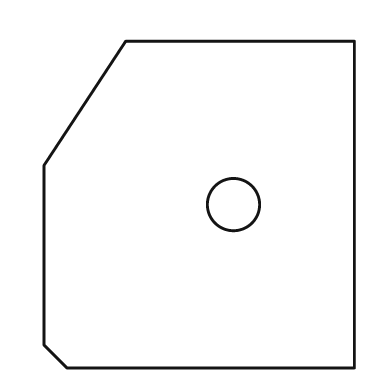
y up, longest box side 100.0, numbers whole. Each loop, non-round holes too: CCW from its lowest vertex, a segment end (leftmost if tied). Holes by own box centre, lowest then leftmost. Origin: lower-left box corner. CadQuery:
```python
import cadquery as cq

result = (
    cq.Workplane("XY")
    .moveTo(7.0, 0.0)
    .lineTo(95.0, 0.0)
    .lineTo(95.0, 100.0)
    .lineTo(25.0, 100.0)
    .lineTo(0.0, 62.0)
    .lineTo(0.0, 7.0)
    .close()
    .moveTo(58.0, 50.0)
    .circle(8.0)
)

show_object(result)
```